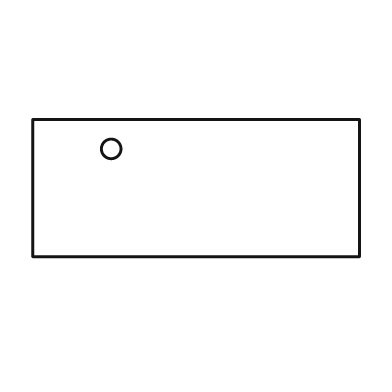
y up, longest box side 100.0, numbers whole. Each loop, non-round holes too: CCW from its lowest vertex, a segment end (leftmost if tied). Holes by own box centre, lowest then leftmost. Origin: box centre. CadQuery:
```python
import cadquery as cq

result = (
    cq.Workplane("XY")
    .moveTo(-50.0, -21.0)
    .lineTo(50.0, -21.0)
    .lineTo(50.0, 21.0)
    .lineTo(-50.0, 21.0)
    .close()
    .moveTo(-26.0, 12.0)
    .circle(3.0)
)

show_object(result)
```